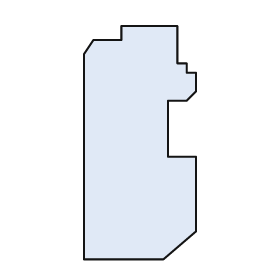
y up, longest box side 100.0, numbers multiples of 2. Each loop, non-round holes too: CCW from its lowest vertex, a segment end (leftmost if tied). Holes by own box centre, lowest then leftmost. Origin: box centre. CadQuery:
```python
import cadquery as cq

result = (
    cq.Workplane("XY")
    .moveTo(-24.0, -50.0)
    .lineTo(10.0, -50.0)
    .lineTo(24.0, -38.0)
    .lineTo(24.0, -6.0)
    .lineTo(12.0, -6.0)
    .lineTo(12.0, 18.0)
    .lineTo(20.0, 18.0)
    .lineTo(24.0, 22.0)
    .lineTo(24.0, 30.0)
    .lineTo(20.0, 30.0)
    .lineTo(20.0, 34.0)
    .lineTo(16.0, 34.0)
    .lineTo(16.0, 50.0)
    .lineTo(-8.0, 50.0)
    .lineTo(-8.0, 44.0)
    .lineTo(-20.0, 44.0)
    .lineTo(-24.0, 38.0)
    .close()
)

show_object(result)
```